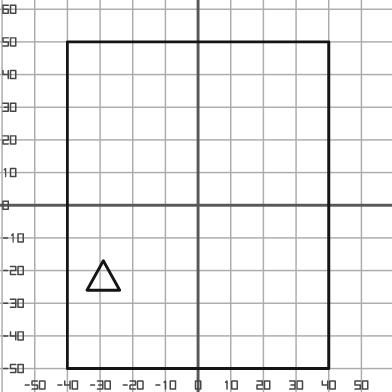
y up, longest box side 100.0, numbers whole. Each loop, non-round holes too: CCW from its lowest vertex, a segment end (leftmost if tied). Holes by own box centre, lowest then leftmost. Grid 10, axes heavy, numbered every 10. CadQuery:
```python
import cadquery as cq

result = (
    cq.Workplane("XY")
    .moveTo(-40.0, -50.0)
    .lineTo(40.0, -50.0)
    .lineTo(40.0, 50.0)
    .lineTo(-40.0, 50.0)
    .close()
    .moveTo(-34.0, -26.0)
    .lineTo(-24.0, -26.0)
    .lineTo(-29.0, -17.0)
    .close()
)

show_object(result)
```